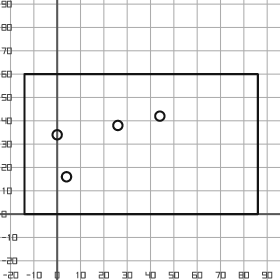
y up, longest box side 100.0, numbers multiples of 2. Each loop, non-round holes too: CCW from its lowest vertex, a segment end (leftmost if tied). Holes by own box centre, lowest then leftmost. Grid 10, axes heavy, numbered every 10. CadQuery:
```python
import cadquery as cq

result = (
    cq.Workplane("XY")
    .moveTo(-14.0, 0.0)
    .lineTo(86.0, 0.0)
    .lineTo(86.0, 60.0)
    .lineTo(-14.0, 60.0)
    .close()
    .moveTo(4.0, 16.0)
    .circle(2.0)
    .moveTo(0.0, 34.0)
    .circle(2.0)
    .moveTo(26.0, 38.0)
    .circle(2.0)
    .moveTo(44.0, 42.0)
    .circle(2.0)
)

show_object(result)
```